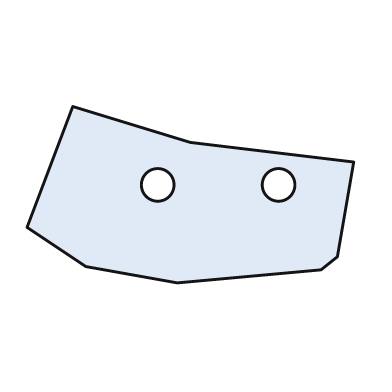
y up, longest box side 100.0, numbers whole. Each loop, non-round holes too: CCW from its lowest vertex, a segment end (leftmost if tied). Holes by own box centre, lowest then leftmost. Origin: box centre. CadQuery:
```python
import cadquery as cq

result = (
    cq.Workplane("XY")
    .moveTo(-4.0, -27.0)
    .lineTo(40.0, -23.0)
    .lineTo(45.0, -19.0)
    .lineTo(50.0, 10.0)
    .lineTo(0.0, 16.0)
    .lineTo(-36.0, 27.0)
    .lineTo(-50.0, -10.0)
    .lineTo(-32.0, -22.0)
    .close()
    .moveTo(-10.0, 3.0)
    .circle(5.0)
    .moveTo(27.0, 3.0)
    .circle(5.0)
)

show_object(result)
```